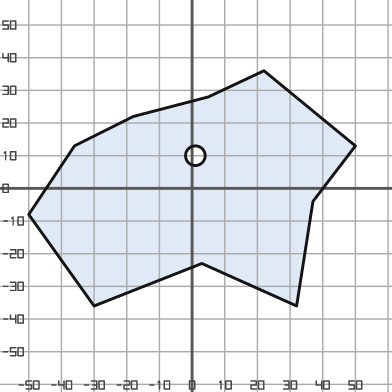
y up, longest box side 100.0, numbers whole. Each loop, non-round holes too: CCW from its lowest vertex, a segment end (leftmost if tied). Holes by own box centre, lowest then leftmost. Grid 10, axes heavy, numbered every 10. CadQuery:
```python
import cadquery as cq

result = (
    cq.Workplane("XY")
    .moveTo(-30.0, -36.0)
    .lineTo(3.0, -23.0)
    .lineTo(32.0, -36.0)
    .lineTo(37.0, -4.0)
    .lineTo(50.0, 13.0)
    .lineTo(22.0, 36.0)
    .lineTo(5.0, 28.0)
    .lineTo(-18.0, 22.0)
    .lineTo(-36.0, 13.0)
    .lineTo(-50.0, -8.0)
    .close()
    .moveTo(1.0, 10.0)
    .circle(3.0)
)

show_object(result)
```